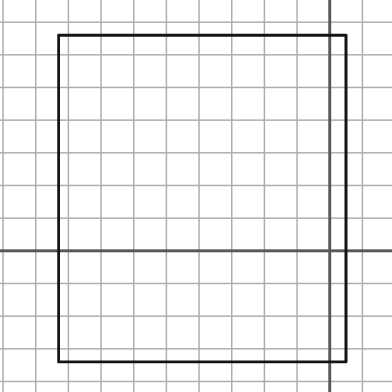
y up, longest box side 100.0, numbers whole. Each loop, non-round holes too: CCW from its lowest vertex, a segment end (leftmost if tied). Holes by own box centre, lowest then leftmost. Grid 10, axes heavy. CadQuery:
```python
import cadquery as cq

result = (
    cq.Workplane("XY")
    .moveTo(-83.0, -34.0)
    .lineTo(5.0, -34.0)
    .lineTo(5.0, 66.0)
    .lineTo(-83.0, 66.0)
    .close()
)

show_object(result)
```